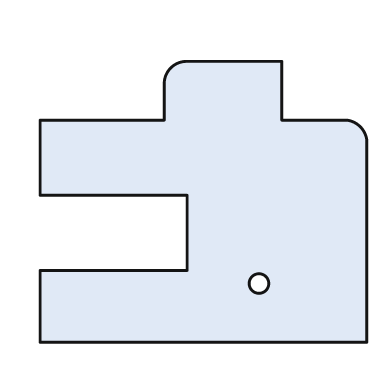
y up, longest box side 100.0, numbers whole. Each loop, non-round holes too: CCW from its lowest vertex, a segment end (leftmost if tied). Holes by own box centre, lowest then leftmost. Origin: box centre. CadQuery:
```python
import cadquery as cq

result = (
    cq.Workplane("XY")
    .moveTo(-50.0, -43.0)
    .lineTo(50.0, -43.0)
    .lineTo(50.0, 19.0)
    .threePointArc((48.0, 23.0), (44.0, 25.0))
    .lineTo(24.0, 25.0)
    .lineTo(24.0, 43.0)
    .lineTo(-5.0, 43.0)
    .threePointArc((-10.0, 41.0), (-12.0, 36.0))
    .lineTo(-12.0, 25.0)
    .lineTo(-50.0, 25.0)
    .lineTo(-50.0, 2.0)
    .lineTo(-5.0, 2.0)
    .lineTo(-5.0, -21.0)
    .lineTo(-50.0, -21.0)
    .close()
    .moveTo(17.0, -25.0)
    .circle(3.0)
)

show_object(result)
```